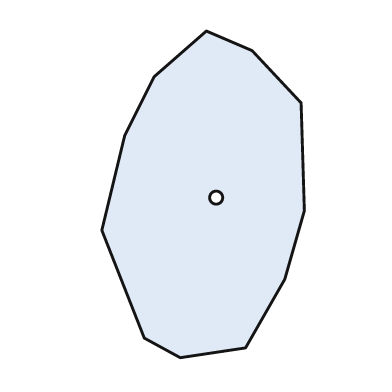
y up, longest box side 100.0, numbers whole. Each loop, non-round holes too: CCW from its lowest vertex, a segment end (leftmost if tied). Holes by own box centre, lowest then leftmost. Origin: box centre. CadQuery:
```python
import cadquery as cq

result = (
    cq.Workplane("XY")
    .moveTo(-7.0, -50.0)
    .lineTo(13.0, -47.0)
    .lineTo(25.0, -26.0)
    .lineTo(31.0, -5.0)
    .lineTo(30.0, 28.0)
    .lineTo(15.0, 44.0)
    .lineTo(1.0, 50.0)
    .lineTo(-15.0, 36.0)
    .lineTo(-24.0, 18.0)
    .lineTo(-31.0, -11.0)
    .lineTo(-18.0, -44.0)
    .close()
    .moveTo(4.0, -1.0)
    .circle(2.0)
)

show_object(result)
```